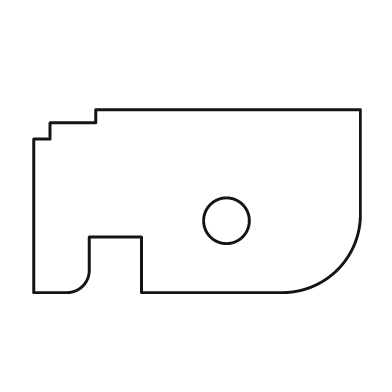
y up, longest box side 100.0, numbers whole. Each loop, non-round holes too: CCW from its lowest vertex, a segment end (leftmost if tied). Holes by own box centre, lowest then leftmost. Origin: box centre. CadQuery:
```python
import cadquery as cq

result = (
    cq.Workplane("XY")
    .moveTo(-50.0, -28.0)
    .lineTo(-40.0, -28.0)
    .threePointArc((-35.0, -26.0), (-33.0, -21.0))
    .lineTo(-33.0, -11.0)
    .lineTo(-17.0, -11.0)
    .lineTo(-17.0, -28.0)
    .lineTo(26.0, -28.0)
    .threePointArc((43.0, -21.0), (50.0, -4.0))
    .lineTo(50.0, 28.0)
    .lineTo(-31.0, 28.0)
    .lineTo(-31.0, 24.0)
    .lineTo(-45.0, 24.0)
    .lineTo(-45.0, 19.0)
    .lineTo(-50.0, 19.0)
    .close()
    .moveTo(9.0, -6.0)
    .circle(7.0)
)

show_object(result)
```